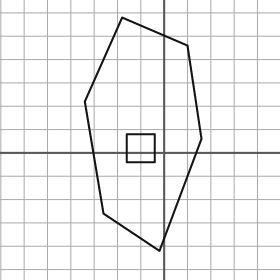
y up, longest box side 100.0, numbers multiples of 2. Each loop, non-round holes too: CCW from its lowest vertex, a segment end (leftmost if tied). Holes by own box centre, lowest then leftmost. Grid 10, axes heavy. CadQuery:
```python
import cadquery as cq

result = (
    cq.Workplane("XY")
    .moveTo(-2.0, -42.0)
    .lineTo(16.0, 6.0)
    .lineTo(10.0, 46.0)
    .lineTo(-18.0, 58.0)
    .lineTo(-34.0, 22.0)
    .lineTo(-26.0, -26.0)
    .close()
    .moveTo(-16.0, -4.0)
    .lineTo(-4.0, -4.0)
    .lineTo(-4.0, 8.0)
    .lineTo(-16.0, 8.0)
    .close()
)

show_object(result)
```